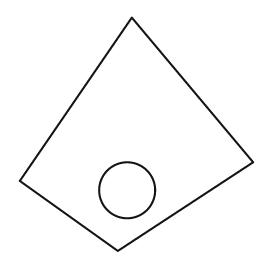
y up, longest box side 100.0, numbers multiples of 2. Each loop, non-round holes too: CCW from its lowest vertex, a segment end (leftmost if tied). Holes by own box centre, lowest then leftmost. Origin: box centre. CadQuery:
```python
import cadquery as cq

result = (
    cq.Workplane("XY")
    .moveTo(-8.0, -50.0)
    .lineTo(50.0, -12.0)
    .lineTo(-2.0, 50.0)
    .lineTo(-50.0, -20.0)
    .close()
    .moveTo(-4.0, -24.0)
    .circle(12.0)
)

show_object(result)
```